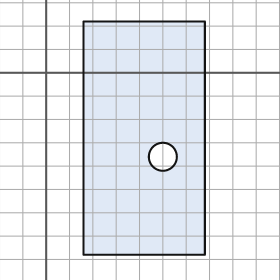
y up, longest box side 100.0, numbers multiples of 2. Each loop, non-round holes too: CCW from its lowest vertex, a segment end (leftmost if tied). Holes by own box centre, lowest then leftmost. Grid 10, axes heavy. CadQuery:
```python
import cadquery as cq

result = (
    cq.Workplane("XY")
    .moveTo(16.0, -78.0)
    .lineTo(68.0, -78.0)
    .lineTo(68.0, 22.0)
    .lineTo(16.0, 22.0)
    .close()
    .moveTo(50.0, -36.0)
    .circle(6.0)
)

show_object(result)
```